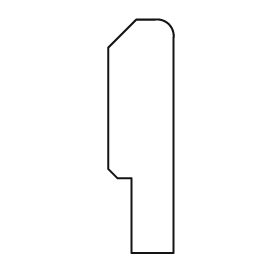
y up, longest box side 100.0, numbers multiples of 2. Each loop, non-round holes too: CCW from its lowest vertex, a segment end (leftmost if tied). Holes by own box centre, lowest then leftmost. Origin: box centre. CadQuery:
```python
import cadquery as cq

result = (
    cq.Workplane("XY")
    .moveTo(-4.0, -50.0)
    .lineTo(14.0, -50.0)
    .lineTo(14.0, 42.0)
    .threePointArc((12.0, 48.0), (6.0, 50.0))
    .lineTo(-2.0, 50.0)
    .lineTo(-14.0, 38.0)
    .lineTo(-14.0, -14.0)
    .lineTo(-10.0, -18.0)
    .lineTo(-4.0, -18.0)
    .close()
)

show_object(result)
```